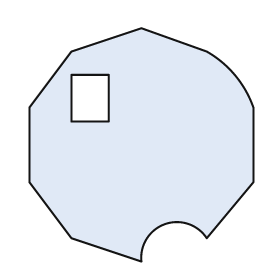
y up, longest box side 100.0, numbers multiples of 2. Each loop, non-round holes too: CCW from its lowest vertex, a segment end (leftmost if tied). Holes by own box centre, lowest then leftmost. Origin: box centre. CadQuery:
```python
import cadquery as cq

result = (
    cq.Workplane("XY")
    .moveTo(0.0, -50.0)
    .threePointArc((10.0, -34.0), (28.0, -40.0))
    .lineTo(48.0, -16.0)
    .lineTo(48.0, 16.0)
    .threePointArc((40.0, 30.0), (28.0, 40.0))
    .lineTo(0.0, 50.0)
    .lineTo(-30.0, 40.0)
    .lineTo(-48.0, 16.0)
    .lineTo(-48.0, -16.0)
    .lineTo(-30.0, -40.0)
    .close()
    .moveTo(-30.0, 10.0)
    .lineTo(-14.0, 10.0)
    .lineTo(-14.0, 30.0)
    .lineTo(-30.0, 30.0)
    .close()
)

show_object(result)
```